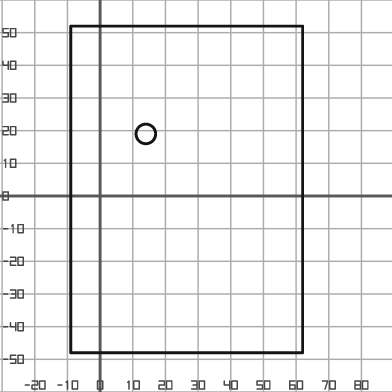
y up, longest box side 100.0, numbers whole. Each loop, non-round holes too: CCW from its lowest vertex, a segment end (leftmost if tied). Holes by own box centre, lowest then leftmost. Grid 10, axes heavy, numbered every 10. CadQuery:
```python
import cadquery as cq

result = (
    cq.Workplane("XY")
    .moveTo(-9.0, -48.0)
    .lineTo(62.0, -48.0)
    .lineTo(62.0, 52.0)
    .lineTo(-9.0, 52.0)
    .close()
    .moveTo(14.0, 19.0)
    .circle(3.0)
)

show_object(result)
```